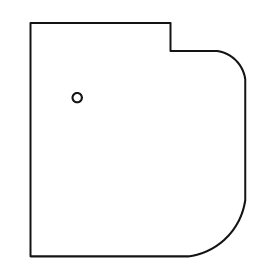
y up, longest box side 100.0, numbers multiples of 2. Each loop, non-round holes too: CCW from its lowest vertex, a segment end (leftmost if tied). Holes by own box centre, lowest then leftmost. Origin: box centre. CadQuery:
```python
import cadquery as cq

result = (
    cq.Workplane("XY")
    .moveTo(-46.0, -50.0)
    .lineTo(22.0, -50.0)
    .threePointArc((38.0, -42.0), (46.0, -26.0))
    .lineTo(46.0, 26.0)
    .threePointArc((42.0, 34.0), (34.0, 38.0))
    .lineTo(14.0, 38.0)
    .lineTo(14.0, 50.0)
    .lineTo(-46.0, 50.0)
    .close()
    .moveTo(-26.0, 18.0)
    .circle(2.0)
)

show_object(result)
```